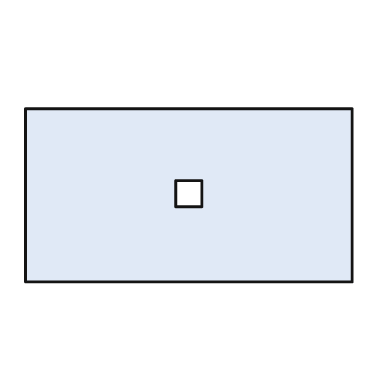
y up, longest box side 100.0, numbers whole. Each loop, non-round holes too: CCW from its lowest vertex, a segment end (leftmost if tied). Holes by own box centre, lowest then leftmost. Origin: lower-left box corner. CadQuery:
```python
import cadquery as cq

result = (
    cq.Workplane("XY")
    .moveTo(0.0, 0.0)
    .lineTo(100.0, 0.0)
    .lineTo(100.0, 53.0)
    .lineTo(0.0, 53.0)
    .close()
    .moveTo(46.0, 23.0)
    .lineTo(54.0, 23.0)
    .lineTo(54.0, 31.0)
    .lineTo(46.0, 31.0)
    .close()
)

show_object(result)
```